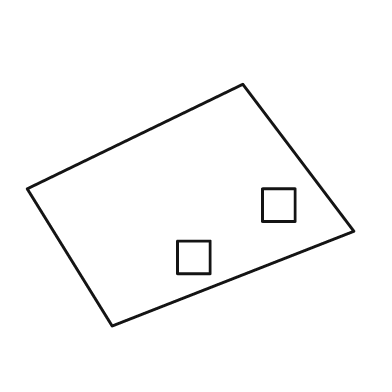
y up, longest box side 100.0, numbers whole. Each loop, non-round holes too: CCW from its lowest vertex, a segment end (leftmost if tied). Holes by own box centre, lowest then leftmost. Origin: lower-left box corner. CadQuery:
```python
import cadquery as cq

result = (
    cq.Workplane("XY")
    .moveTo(26.0, 0.0)
    .lineTo(100.0, 29.0)
    .lineTo(66.0, 74.0)
    .lineTo(0.0, 42.0)
    .close()
    .moveTo(46.0, 16.0)
    .lineTo(56.0, 16.0)
    .lineTo(56.0, 26.0)
    .lineTo(46.0, 26.0)
    .close()
    .moveTo(72.0, 32.0)
    .lineTo(82.0, 32.0)
    .lineTo(82.0, 42.0)
    .lineTo(72.0, 42.0)
    .close()
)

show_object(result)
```